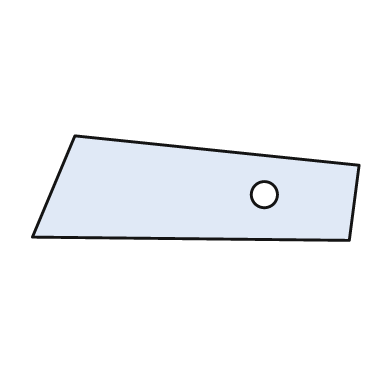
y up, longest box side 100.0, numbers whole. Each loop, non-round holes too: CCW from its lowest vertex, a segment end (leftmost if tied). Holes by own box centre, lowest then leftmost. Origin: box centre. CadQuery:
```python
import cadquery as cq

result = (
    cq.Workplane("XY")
    .moveTo(47.0, -16.0)
    .lineTo(50.0, 7.0)
    .lineTo(-37.0, 16.0)
    .lineTo(-50.0, -15.0)
    .close()
    .moveTo(21.0, -2.0)
    .circle(4.0)
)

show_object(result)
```